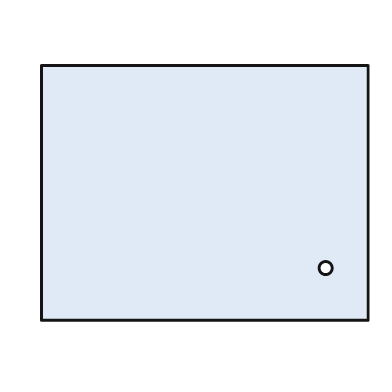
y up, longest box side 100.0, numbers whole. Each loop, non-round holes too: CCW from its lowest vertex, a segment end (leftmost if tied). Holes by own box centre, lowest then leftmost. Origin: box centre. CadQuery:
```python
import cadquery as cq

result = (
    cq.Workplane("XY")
    .moveTo(-50.0, -39.0)
    .lineTo(50.0, -39.0)
    .lineTo(50.0, 39.0)
    .lineTo(-50.0, 39.0)
    .close()
    .moveTo(37.0, -23.0)
    .circle(2.0)
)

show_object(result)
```